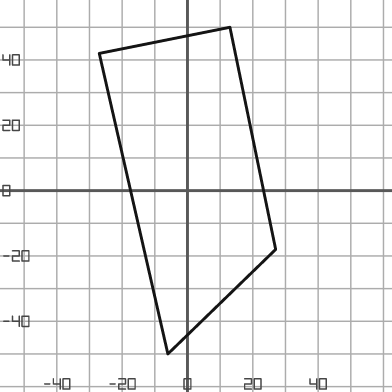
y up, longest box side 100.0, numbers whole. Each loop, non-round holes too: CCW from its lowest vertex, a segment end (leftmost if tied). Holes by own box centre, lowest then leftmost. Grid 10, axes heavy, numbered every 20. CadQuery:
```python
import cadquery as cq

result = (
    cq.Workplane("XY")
    .moveTo(-6.0, -50.0)
    .lineTo(27.0, -18.0)
    .lineTo(13.0, 50.0)
    .lineTo(-27.0, 42.0)
    .close()
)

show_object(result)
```